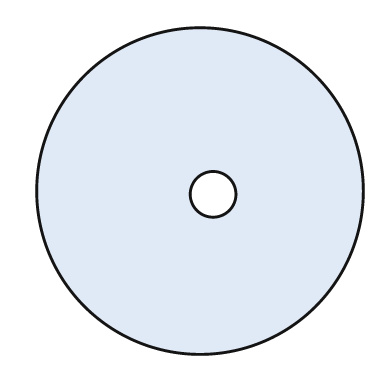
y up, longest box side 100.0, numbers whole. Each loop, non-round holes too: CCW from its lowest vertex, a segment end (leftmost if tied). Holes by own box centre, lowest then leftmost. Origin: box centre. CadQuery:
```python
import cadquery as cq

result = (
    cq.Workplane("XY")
    .moveTo(0.0, 0.0)
    .circle(50.0)
    .moveTo(4.0, -1.0)
    .circle(7.0)
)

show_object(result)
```